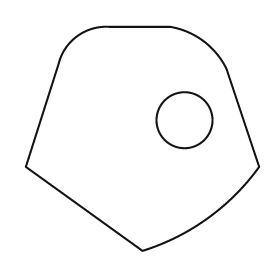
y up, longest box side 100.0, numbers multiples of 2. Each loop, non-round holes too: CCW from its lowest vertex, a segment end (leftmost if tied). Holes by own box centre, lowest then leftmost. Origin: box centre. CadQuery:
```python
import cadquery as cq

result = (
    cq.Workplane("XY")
    .moveTo(0.0, -48.0)
    .threePointArc((28.0, -34.0), (50.0, -12.0))
    .lineTo(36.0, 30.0)
    .threePointArc((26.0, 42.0), (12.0, 48.0))
    .lineTo(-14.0, 48.0)
    .threePointArc((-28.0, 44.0), (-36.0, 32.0))
    .lineTo(-50.0, -12.0)
    .close()
    .moveTo(18.0, 8.0)
    .circle(12.0)
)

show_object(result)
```